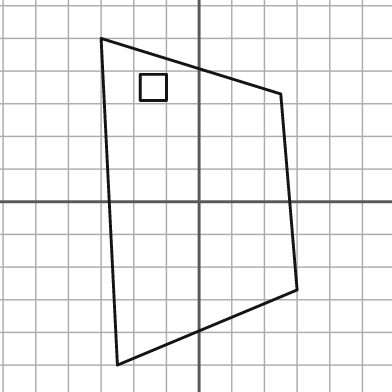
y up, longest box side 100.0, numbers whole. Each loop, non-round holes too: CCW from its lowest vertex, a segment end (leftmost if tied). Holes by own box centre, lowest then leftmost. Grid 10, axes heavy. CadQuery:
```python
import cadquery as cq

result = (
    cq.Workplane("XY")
    .moveTo(-25.0, -50.0)
    .lineTo(30.0, -27.0)
    .lineTo(25.0, 33.0)
    .lineTo(-30.0, 50.0)
    .close()
    .moveTo(-18.0, 31.0)
    .lineTo(-10.0, 31.0)
    .lineTo(-10.0, 39.0)
    .lineTo(-18.0, 39.0)
    .close()
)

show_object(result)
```